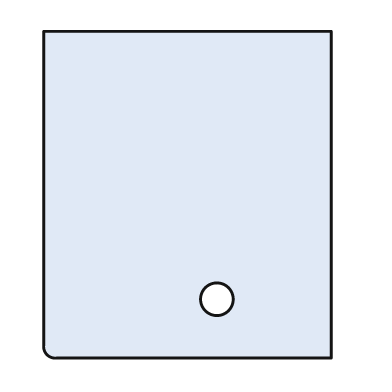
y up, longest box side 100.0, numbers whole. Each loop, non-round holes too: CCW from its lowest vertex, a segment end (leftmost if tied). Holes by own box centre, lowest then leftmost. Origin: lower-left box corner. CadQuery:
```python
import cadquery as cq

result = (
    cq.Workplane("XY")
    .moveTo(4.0, 0.0)
    .lineTo(88.0, 0.0)
    .lineTo(88.0, 100.0)
    .lineTo(0.0, 100.0)
    .lineTo(0.0, 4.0)
    .threePointArc((1.0, 1.0), (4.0, 0.0))
    .close()
    .moveTo(53.0, 18.0)
    .circle(5.0)
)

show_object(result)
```